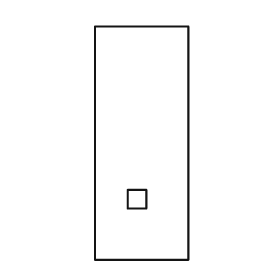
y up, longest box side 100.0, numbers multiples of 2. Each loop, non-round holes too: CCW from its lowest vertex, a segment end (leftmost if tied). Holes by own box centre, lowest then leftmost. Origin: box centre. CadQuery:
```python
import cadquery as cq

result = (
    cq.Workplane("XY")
    .moveTo(-20.0, -50.0)
    .lineTo(20.0, -50.0)
    .lineTo(20.0, 50.0)
    .lineTo(-20.0, 50.0)
    .close()
    .moveTo(-6.0, -28.0)
    .lineTo(2.0, -28.0)
    .lineTo(2.0, -20.0)
    .lineTo(-6.0, -20.0)
    .close()
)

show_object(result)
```